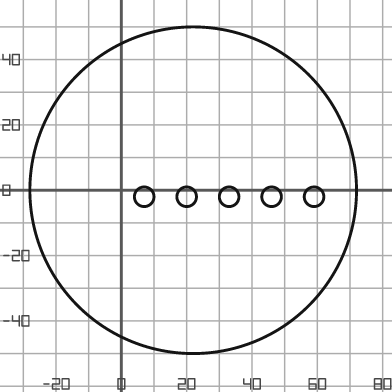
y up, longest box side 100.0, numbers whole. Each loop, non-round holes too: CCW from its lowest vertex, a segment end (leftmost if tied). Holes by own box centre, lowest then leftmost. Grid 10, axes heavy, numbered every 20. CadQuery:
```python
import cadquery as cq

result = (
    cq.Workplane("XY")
    .moveTo(22.0, 0.0)
    .circle(50.0)
    .moveTo(7.0, -2.0)
    .circle(3.0)
    .moveTo(20.0, -2.0)
    .circle(3.0)
    .moveTo(33.0, -2.0)
    .circle(3.0)
    .moveTo(46.0, -2.0)
    .circle(3.0)
    .moveTo(59.0, -2.0)
    .circle(3.0)
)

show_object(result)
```